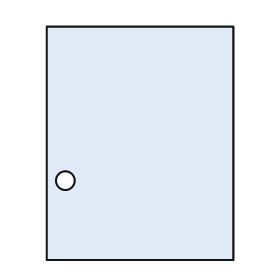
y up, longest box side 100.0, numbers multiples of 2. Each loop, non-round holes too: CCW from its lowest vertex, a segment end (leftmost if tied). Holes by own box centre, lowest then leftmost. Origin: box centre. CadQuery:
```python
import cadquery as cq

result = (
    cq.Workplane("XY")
    .moveTo(-40.0, -50.0)
    .lineTo(40.0, -50.0)
    .lineTo(40.0, 50.0)
    .lineTo(-40.0, 50.0)
    .close()
    .moveTo(-32.0, -16.0)
    .circle(4.0)
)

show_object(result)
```